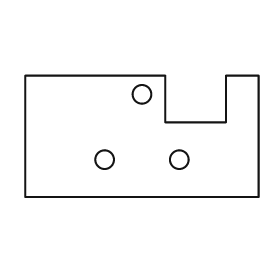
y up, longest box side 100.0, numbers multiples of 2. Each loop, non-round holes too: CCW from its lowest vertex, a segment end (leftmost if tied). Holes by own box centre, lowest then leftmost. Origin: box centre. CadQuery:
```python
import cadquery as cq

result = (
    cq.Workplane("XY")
    .moveTo(-50.0, -26.0)
    .lineTo(50.0, -26.0)
    .lineTo(50.0, 26.0)
    .lineTo(36.0, 26.0)
    .lineTo(36.0, 6.0)
    .lineTo(10.0, 6.0)
    .lineTo(10.0, 26.0)
    .lineTo(-50.0, 26.0)
    .close()
    .moveTo(-16.0, -10.0)
    .circle(4.0)
    .moveTo(16.0, -10.0)
    .circle(4.0)
    .moveTo(0.0, 18.0)
    .circle(4.0)
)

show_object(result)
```